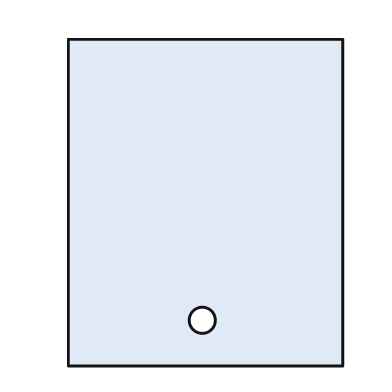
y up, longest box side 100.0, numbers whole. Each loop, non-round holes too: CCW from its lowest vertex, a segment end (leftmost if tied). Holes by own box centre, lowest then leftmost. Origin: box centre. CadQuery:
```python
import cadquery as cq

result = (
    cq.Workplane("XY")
    .moveTo(-42.0, -50.0)
    .lineTo(42.0, -50.0)
    .lineTo(42.0, 50.0)
    .lineTo(-42.0, 50.0)
    .close()
    .moveTo(-1.0, -36.0)
    .circle(4.0)
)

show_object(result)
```